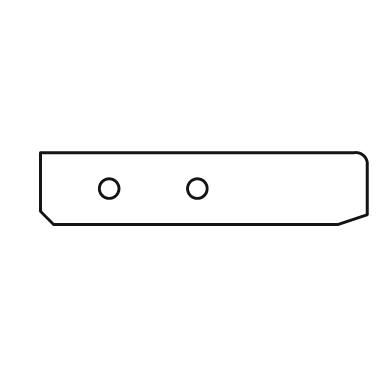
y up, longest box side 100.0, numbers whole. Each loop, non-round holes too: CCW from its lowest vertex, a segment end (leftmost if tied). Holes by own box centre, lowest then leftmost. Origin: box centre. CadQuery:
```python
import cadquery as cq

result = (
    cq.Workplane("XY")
    .moveTo(-46.0, -11.0)
    .lineTo(41.0, -11.0)
    .lineTo(50.0, -8.0)
    .lineTo(50.0, 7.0)
    .threePointArc((49.0, 10.0), (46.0, 11.0))
    .lineTo(-50.0, 11.0)
    .lineTo(-50.0, -7.0)
    .close()
    .moveTo(-29.0, 0.0)
    .circle(3.0)
    .moveTo(-2.0, 0.0)
    .circle(3.0)
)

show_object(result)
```